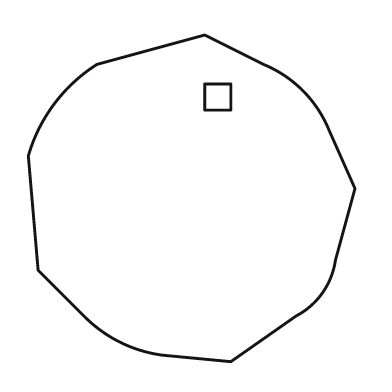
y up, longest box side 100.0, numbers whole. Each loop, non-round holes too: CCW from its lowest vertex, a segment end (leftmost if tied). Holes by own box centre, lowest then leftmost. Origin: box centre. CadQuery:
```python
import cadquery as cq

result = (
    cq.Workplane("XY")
    .moveTo(12.0, -50.0)
    .lineTo(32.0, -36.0)
    .threePointArc((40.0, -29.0), (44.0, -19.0))
    .lineTo(50.0, 3.0)
    .lineTo(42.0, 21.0)
    .threePointArc((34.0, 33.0), (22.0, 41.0))
    .lineTo(4.0, 50.0)
    .lineTo(-29.0, 41.0)
    .threePointArc((-42.0, 29.0), (-50.0, 13.0))
    .lineTo(-47.0, -22.0)
    .lineTo(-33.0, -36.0)
    .threePointArc((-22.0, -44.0), (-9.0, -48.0))
    .close()
    .moveTo(4.0, 27.0)
    .lineTo(12.0, 27.0)
    .lineTo(12.0, 35.0)
    .lineTo(4.0, 35.0)
    .close()
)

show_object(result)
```